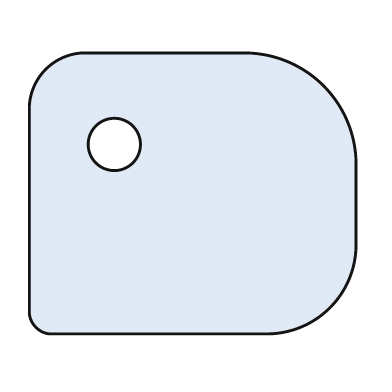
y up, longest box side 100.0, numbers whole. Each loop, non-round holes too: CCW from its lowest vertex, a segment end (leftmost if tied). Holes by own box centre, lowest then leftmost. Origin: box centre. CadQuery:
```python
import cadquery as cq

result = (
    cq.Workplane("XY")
    .moveTo(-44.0, -43.0)
    .lineTo(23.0, -43.0)
    .threePointArc((42.0, -35.0), (50.0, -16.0))
    .lineTo(50.0, 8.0)
    .threePointArc((40.0, 33.0), (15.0, 43.0))
    .lineTo(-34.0, 43.0)
    .threePointArc((-45.0, 38.0), (-50.0, 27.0))
    .lineTo(-50.0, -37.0)
    .threePointArc((-48.0, -41.0), (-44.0, -43.0))
    .close()
    .moveTo(-24.0, 15.0)
    .circle(8.0)
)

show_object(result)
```